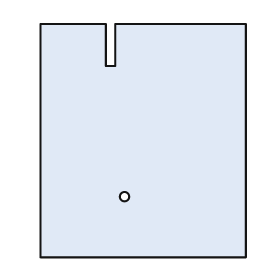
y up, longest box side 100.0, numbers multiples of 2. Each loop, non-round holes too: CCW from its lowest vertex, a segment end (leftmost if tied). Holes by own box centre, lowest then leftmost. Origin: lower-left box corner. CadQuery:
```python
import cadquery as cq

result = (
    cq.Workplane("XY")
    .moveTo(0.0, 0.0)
    .lineTo(88.0, 0.0)
    .lineTo(88.0, 100.0)
    .lineTo(32.0, 100.0)
    .lineTo(32.0, 82.0)
    .lineTo(28.0, 82.0)
    .lineTo(28.0, 100.0)
    .lineTo(0.0, 100.0)
    .close()
    .moveTo(36.0, 26.0)
    .circle(2.0)
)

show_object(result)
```